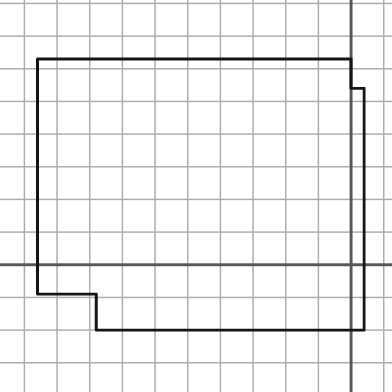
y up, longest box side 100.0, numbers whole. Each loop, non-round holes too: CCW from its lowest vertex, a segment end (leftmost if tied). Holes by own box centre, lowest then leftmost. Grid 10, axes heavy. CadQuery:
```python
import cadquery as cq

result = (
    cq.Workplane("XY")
    .moveTo(-78.0, -20.0)
    .lineTo(4.0, -20.0)
    .lineTo(4.0, 54.0)
    .lineTo(0.0, 54.0)
    .lineTo(0.0, 63.0)
    .lineTo(-96.0, 63.0)
    .lineTo(-96.0, -9.0)
    .lineTo(-78.0, -9.0)
    .close()
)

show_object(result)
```